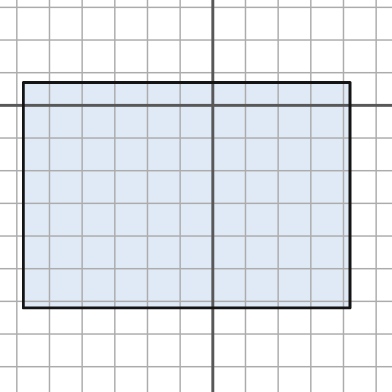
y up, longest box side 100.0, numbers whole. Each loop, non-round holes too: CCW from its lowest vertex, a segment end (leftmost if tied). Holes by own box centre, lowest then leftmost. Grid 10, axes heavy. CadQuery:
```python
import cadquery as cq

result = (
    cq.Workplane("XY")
    .moveTo(-58.0, -62.0)
    .lineTo(42.0, -62.0)
    .lineTo(42.0, 7.0)
    .lineTo(-58.0, 7.0)
    .close()
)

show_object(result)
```